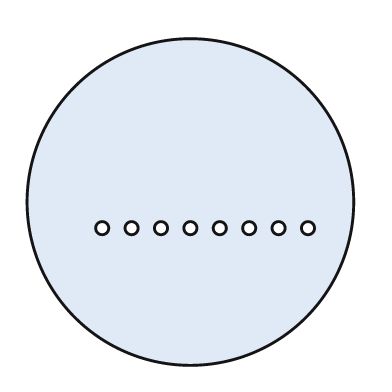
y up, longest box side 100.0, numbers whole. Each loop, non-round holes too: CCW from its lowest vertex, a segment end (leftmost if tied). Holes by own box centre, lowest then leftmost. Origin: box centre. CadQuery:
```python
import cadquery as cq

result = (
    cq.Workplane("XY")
    .moveTo(0.0, 0.0)
    .circle(50.0)
    .moveTo(-27.0, -8.0)
    .circle(2.0)
    .moveTo(-18.0, -8.0)
    .circle(2.0)
    .moveTo(-9.0, -8.0)
    .circle(2.0)
    .moveTo(0.0, -8.0)
    .circle(2.0)
    .moveTo(9.0, -8.0)
    .circle(2.0)
    .moveTo(18.0, -8.0)
    .circle(2.0)
    .moveTo(27.0, -8.0)
    .circle(2.0)
    .moveTo(36.0, -8.0)
    .circle(2.0)
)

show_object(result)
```